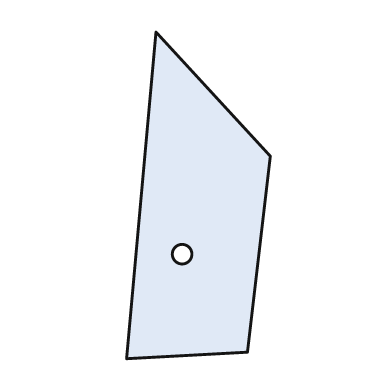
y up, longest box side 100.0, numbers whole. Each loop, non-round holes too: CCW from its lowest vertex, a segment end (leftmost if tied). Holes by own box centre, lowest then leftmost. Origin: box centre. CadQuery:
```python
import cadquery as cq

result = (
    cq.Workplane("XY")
    .moveTo(-22.0, -50.0)
    .lineTo(15.0, -48.0)
    .lineTo(22.0, 12.0)
    .lineTo(-13.0, 50.0)
    .close()
    .moveTo(-5.0, -18.0)
    .circle(3.0)
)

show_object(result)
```